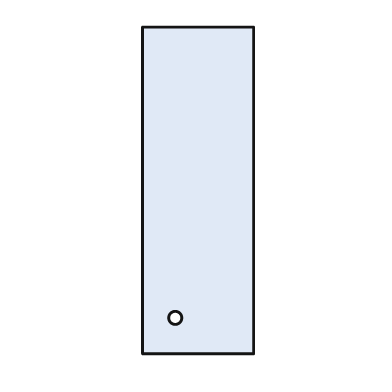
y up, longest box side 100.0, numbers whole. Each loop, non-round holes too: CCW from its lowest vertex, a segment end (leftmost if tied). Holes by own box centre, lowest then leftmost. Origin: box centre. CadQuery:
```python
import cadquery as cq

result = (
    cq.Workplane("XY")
    .moveTo(-17.0, -50.0)
    .lineTo(17.0, -50.0)
    .lineTo(17.0, 50.0)
    .lineTo(-17.0, 50.0)
    .close()
    .moveTo(-7.0, -39.0)
    .circle(2.0)
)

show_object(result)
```